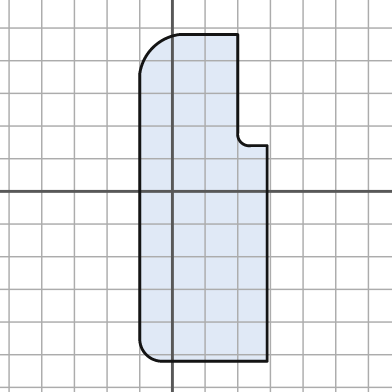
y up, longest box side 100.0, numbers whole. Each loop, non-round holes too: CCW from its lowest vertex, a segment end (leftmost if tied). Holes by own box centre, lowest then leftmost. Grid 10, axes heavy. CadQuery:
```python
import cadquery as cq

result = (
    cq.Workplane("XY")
    .moveTo(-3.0, -52.0)
    .lineTo(29.0, -52.0)
    .lineTo(29.0, 14.0)
    .lineTo(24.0, 14.0)
    .threePointArc((21.0, 15.0), (20.0, 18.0))
    .lineTo(20.0, 48.0)
    .lineTo(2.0, 48.0)
    .threePointArc((-6.0, 44.0), (-10.0, 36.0))
    .lineTo(-10.0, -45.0)
    .threePointArc((-8.0, -50.0), (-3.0, -52.0))
    .close()
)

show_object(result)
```